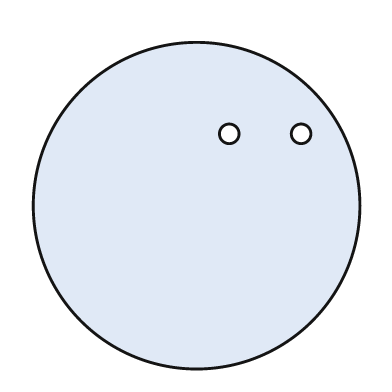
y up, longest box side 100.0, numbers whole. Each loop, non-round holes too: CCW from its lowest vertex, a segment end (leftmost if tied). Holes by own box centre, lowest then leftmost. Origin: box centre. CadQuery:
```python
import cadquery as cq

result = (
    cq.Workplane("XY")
    .moveTo(0.0, 0.0)
    .circle(50.0)
    .moveTo(10.0, 22.0)
    .circle(3.0)
    .moveTo(32.0, 22.0)
    .circle(3.0)
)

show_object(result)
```